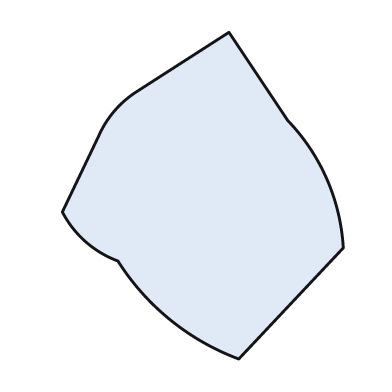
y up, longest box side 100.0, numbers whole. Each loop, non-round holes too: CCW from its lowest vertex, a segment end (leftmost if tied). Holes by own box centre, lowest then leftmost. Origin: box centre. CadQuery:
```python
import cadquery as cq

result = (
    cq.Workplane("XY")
    .moveTo(11.0, -50.0)
    .lineTo(43.0, -16.0)
    .threePointArc((38.0, 5.0), (26.0, 23.0))
    .lineTo(8.0, 50.0)
    .lineTo(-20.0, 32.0)
    .threePointArc((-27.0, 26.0), (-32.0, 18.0))
    .lineTo(-43.0, -5.0)
    .threePointArc((-36.0, -14.0), (-26.0, -20.0))
    .threePointArc((-10.0, -38.0), (11.0, -50.0))
    .close()
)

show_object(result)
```